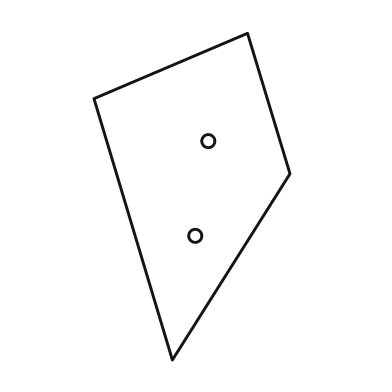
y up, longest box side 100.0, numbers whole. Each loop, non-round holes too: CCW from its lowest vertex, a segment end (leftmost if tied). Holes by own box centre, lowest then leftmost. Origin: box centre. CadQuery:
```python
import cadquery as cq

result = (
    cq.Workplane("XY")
    .moveTo(-6.0, -50.0)
    .lineTo(30.0, 7.0)
    .lineTo(17.0, 50.0)
    .lineTo(-30.0, 30.0)
    .close()
    .moveTo(1.0, -12.0)
    .circle(2.0)
    .moveTo(5.0, 17.0)
    .circle(2.0)
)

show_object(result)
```